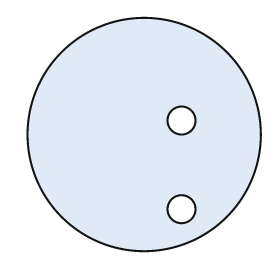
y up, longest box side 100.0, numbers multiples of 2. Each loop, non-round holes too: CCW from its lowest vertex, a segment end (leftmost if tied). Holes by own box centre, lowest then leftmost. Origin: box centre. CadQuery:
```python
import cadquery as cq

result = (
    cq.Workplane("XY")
    .moveTo(0.0, 0.0)
    .circle(50.0)
    .moveTo(16.0, -32.0)
    .circle(6.0)
    .moveTo(16.0, 6.0)
    .circle(6.0)
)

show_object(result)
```